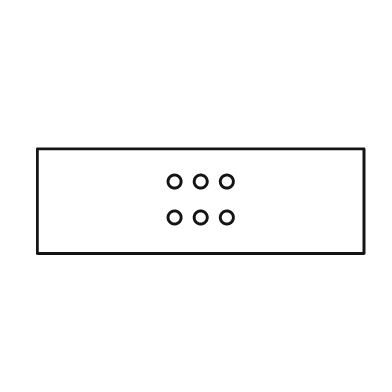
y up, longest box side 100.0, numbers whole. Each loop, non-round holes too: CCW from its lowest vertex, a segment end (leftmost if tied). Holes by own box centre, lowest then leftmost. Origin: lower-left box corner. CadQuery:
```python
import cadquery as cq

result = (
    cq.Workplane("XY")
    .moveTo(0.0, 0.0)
    .lineTo(100.0, 0.0)
    .lineTo(100.0, 32.0)
    .lineTo(0.0, 32.0)
    .close()
    .moveTo(42.0, 11.0)
    .circle(2.0)
    .moveTo(50.0, 11.0)
    .circle(2.0)
    .moveTo(58.0, 11.0)
    .circle(2.0)
    .moveTo(42.0, 22.0)
    .circle(2.0)
    .moveTo(50.0, 22.0)
    .circle(2.0)
    .moveTo(58.0, 22.0)
    .circle(2.0)
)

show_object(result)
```